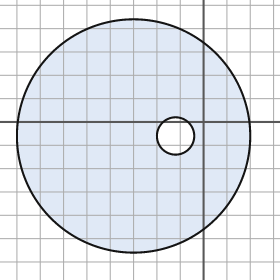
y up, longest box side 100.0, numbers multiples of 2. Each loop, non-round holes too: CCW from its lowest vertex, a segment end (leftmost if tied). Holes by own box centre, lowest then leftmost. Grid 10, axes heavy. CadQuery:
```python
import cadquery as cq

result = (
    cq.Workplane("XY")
    .moveTo(-30.0, -6.0)
    .circle(50.0)
    .moveTo(-12.0, -6.0)
    .circle(8.0)
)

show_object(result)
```